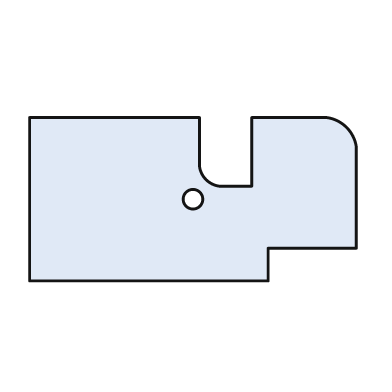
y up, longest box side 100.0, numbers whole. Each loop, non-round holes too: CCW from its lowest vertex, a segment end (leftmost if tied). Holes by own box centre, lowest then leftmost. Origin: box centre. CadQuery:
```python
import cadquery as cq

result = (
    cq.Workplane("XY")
    .moveTo(-50.0, -25.0)
    .lineTo(23.0, -25.0)
    .lineTo(23.0, -15.0)
    .lineTo(50.0, -15.0)
    .lineTo(50.0, 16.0)
    .threePointArc((47.0, 22.0), (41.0, 25.0))
    .lineTo(18.0, 25.0)
    .lineTo(18.0, 4.0)
    .lineTo(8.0, 4.0)
    .threePointArc((4.0, 6.0), (2.0, 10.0))
    .lineTo(2.0, 25.0)
    .lineTo(-50.0, 25.0)
    .close()
    .moveTo(0.0, 0.0)
    .circle(3.0)
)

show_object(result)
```